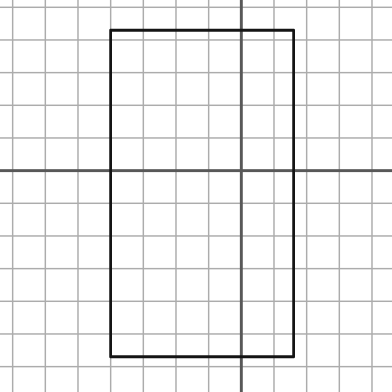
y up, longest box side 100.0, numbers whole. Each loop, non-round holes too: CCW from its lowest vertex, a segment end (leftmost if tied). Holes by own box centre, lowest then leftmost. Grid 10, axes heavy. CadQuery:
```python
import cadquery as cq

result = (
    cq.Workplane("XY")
    .moveTo(-40.0, -57.0)
    .lineTo(16.0, -57.0)
    .lineTo(16.0, 43.0)
    .lineTo(-40.0, 43.0)
    .close()
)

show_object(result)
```